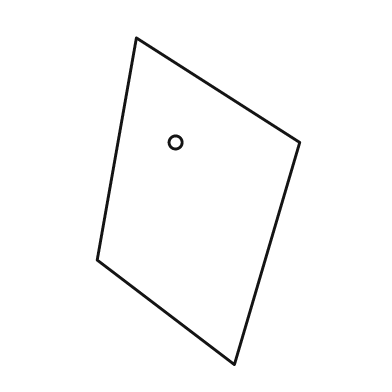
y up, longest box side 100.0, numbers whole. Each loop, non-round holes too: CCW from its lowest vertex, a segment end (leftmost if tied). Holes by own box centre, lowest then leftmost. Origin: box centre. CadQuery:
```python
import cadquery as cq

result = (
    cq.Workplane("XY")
    .moveTo(11.0, -50.0)
    .lineTo(31.0, 18.0)
    .lineTo(-19.0, 50.0)
    .lineTo(-31.0, -18.0)
    .close()
    .moveTo(-7.0, 18.0)
    .circle(2.0)
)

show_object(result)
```